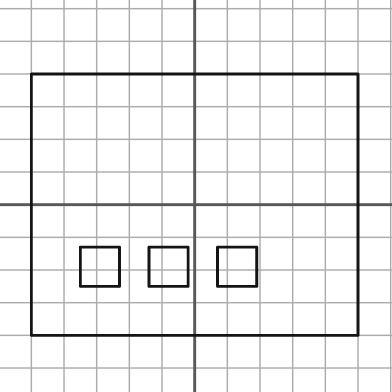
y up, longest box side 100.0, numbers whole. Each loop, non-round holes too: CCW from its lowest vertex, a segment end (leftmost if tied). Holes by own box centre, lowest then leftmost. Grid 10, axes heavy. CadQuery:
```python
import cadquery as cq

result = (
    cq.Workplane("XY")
    .moveTo(-50.0, -40.0)
    .lineTo(50.0, -40.0)
    .lineTo(50.0, 40.0)
    .lineTo(-50.0, 40.0)
    .close()
    .moveTo(-35.0, -25.0)
    .lineTo(-23.0, -25.0)
    .lineTo(-23.0, -13.0)
    .lineTo(-35.0, -13.0)
    .close()
    .moveTo(-14.0, -25.0)
    .lineTo(-2.0, -25.0)
    .lineTo(-2.0, -13.0)
    .lineTo(-14.0, -13.0)
    .close()
    .moveTo(7.0, -25.0)
    .lineTo(19.0, -25.0)
    .lineTo(19.0, -13.0)
    .lineTo(7.0, -13.0)
    .close()
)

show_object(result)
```